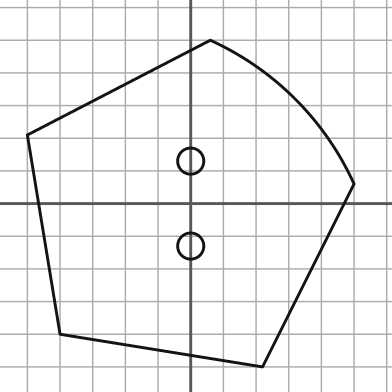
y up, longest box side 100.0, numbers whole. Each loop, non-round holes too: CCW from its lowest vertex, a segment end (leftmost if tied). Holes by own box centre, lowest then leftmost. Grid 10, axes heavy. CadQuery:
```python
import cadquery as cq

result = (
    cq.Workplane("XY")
    .moveTo(22.0, -50.0)
    .lineTo(50.0, 6.0)
    .threePointArc((32.0, 32.0), (6.0, 50.0))
    .lineTo(-50.0, 21.0)
    .lineTo(-40.0, -40.0)
    .close()
    .moveTo(0.0, -13.0)
    .circle(4.0)
    .moveTo(0.0, 13.0)
    .circle(4.0)
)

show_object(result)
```